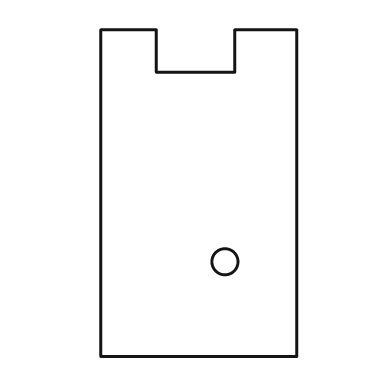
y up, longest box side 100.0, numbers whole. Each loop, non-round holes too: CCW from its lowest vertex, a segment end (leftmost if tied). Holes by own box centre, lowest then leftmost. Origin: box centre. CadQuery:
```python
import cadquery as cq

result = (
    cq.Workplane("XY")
    .moveTo(-30.0, -50.0)
    .lineTo(30.0, -50.0)
    .lineTo(30.0, 50.0)
    .lineTo(11.0, 50.0)
    .lineTo(11.0, 37.0)
    .lineTo(-13.0, 37.0)
    .lineTo(-13.0, 50.0)
    .lineTo(-30.0, 50.0)
    .close()
    .moveTo(8.0, -21.0)
    .circle(4.0)
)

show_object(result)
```